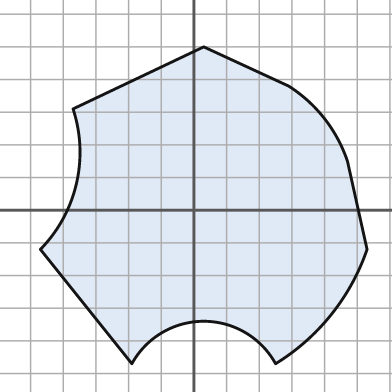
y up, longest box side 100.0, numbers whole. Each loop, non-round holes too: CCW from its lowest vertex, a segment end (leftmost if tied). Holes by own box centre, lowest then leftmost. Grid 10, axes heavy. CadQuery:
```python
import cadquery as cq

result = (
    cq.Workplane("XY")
    .moveTo(-19.0, -47.0)
    .threePointArc((3.0, -34.0), (25.0, -47.0))
    .threePointArc((42.0, -32.0), (53.0, -12.0))
    .lineTo(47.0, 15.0)
    .threePointArc((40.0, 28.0), (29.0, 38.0))
    .lineTo(3.0, 50.0)
    .lineTo(-37.0, 31.0)
    .threePointArc((-36.0, 8.0), (-47.0, -12.0))
    .close()
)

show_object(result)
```